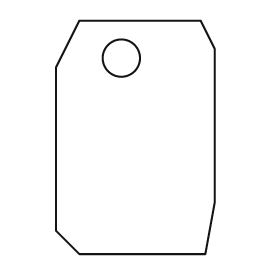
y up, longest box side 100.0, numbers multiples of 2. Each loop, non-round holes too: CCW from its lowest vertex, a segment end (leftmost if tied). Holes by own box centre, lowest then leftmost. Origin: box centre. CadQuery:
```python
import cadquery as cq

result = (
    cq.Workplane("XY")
    .moveTo(-24.0, -50.0)
    .lineTo(30.0, -50.0)
    .lineTo(34.0, -28.0)
    .lineTo(34.0, 38.0)
    .lineTo(28.0, 50.0)
    .lineTo(-24.0, 50.0)
    .lineTo(-34.0, 30.0)
    .lineTo(-34.0, -40.0)
    .close()
    .moveTo(-6.0, 34.0)
    .circle(8.0)
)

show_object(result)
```